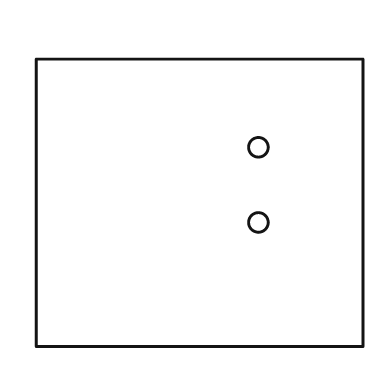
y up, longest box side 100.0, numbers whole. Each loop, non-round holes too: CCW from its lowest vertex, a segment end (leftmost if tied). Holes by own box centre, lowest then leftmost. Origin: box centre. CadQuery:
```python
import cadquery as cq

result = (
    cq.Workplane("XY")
    .moveTo(-50.0, -44.0)
    .lineTo(50.0, -44.0)
    .lineTo(50.0, 44.0)
    .lineTo(-50.0, 44.0)
    .close()
    .moveTo(18.0, -6.0)
    .circle(3.0)
    .moveTo(18.0, 17.0)
    .circle(3.0)
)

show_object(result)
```